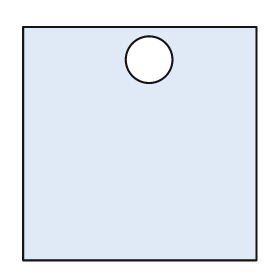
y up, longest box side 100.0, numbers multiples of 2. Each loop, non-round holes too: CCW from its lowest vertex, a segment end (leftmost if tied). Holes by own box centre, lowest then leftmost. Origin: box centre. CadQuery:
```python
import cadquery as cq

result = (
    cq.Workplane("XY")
    .moveTo(-50.0, -50.0)
    .lineTo(50.0, -50.0)
    .lineTo(50.0, 50.0)
    .lineTo(-50.0, 50.0)
    .close()
    .moveTo(4.0, 36.0)
    .circle(10.0)
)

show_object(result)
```